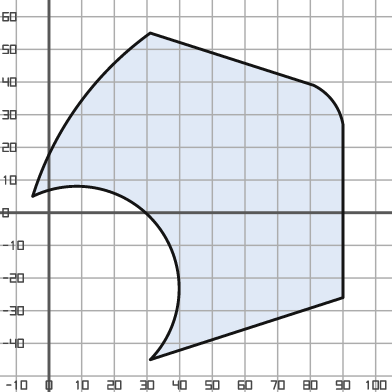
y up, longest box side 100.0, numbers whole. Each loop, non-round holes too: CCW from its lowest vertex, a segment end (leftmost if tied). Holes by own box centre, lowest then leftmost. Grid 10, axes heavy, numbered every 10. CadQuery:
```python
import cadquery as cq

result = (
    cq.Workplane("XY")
    .moveTo(31.0, -45.0)
    .lineTo(90.0, -26.0)
    .lineTo(90.0, 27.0)
    .threePointArc((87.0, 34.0), (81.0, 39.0))
    .lineTo(31.0, 55.0)
    .threePointArc((9.0, 33.0), (-5.0, 5.0))
    .threePointArc((34.0, -5.0), (31.0, -45.0))
    .close()
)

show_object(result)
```